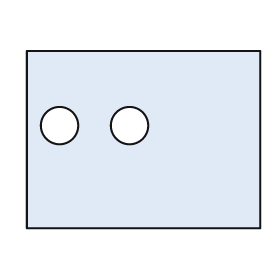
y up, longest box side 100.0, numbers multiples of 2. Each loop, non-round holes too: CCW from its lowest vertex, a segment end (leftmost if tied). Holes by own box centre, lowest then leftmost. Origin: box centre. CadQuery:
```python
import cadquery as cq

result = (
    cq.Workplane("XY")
    .moveTo(-50.0, -38.0)
    .lineTo(50.0, -38.0)
    .lineTo(50.0, 38.0)
    .lineTo(-50.0, 38.0)
    .close()
    .moveTo(-36.0, 6.0)
    .circle(8.0)
    .moveTo(-6.0, 6.0)
    .circle(8.0)
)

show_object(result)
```